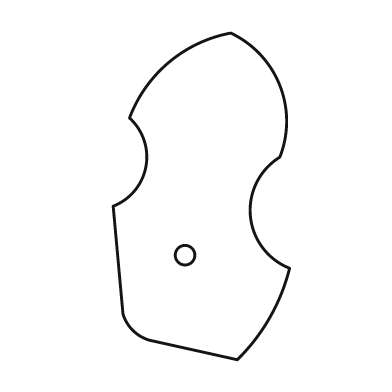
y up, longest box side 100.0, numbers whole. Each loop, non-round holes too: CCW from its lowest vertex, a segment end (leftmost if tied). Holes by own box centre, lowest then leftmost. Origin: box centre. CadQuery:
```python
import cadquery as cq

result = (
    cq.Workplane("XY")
    .moveTo(11.0, -50.0)
    .threePointArc((21.0, -37.0), (27.0, -22.0))
    .threePointArc((15.0, -6.0), (24.0, 12.0))
    .threePointArc((24.0, 34.0), (9.0, 50.0))
    .threePointArc((-10.0, 41.0), (-22.0, 24.0))
    .threePointArc((-17.0, 9.0), (-27.0, -3.0))
    .lineTo(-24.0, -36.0)
    .threePointArc((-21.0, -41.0), (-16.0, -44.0))
    .close()
    .moveTo(-5.0, -18.0)
    .circle(3.0)
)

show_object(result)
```